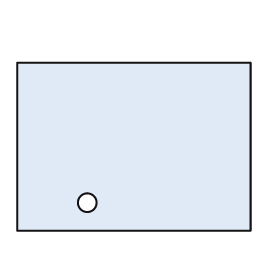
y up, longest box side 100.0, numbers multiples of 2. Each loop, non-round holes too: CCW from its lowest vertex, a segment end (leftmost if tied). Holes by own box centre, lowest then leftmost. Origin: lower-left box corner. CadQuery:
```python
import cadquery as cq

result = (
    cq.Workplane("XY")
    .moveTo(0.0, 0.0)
    .lineTo(100.0, 0.0)
    .lineTo(100.0, 72.0)
    .lineTo(0.0, 72.0)
    .close()
    .moveTo(30.0, 12.0)
    .circle(4.0)
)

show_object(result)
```